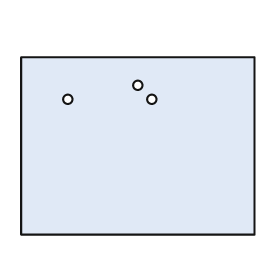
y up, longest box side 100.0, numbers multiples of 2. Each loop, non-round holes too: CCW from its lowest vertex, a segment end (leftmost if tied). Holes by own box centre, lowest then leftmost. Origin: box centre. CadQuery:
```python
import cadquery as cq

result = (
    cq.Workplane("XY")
    .moveTo(-50.0, -38.0)
    .lineTo(50.0, -38.0)
    .lineTo(50.0, 38.0)
    .lineTo(-50.0, 38.0)
    .close()
    .moveTo(-30.0, 20.0)
    .circle(2.0)
    .moveTo(6.0, 20.0)
    .circle(2.0)
    .moveTo(0.0, 26.0)
    .circle(2.0)
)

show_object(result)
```